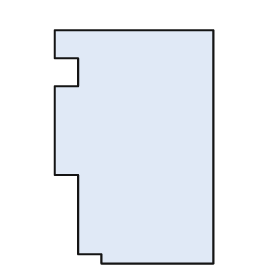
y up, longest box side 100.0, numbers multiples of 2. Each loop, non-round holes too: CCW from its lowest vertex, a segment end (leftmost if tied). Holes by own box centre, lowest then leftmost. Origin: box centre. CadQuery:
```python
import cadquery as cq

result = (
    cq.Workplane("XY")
    .moveTo(-14.0, -50.0)
    .lineTo(34.0, -50.0)
    .lineTo(34.0, 50.0)
    .lineTo(-34.0, 50.0)
    .lineTo(-34.0, 38.0)
    .lineTo(-24.0, 38.0)
    .lineTo(-24.0, 26.0)
    .lineTo(-34.0, 26.0)
    .lineTo(-34.0, -12.0)
    .lineTo(-24.0, -12.0)
    .lineTo(-24.0, -46.0)
    .lineTo(-14.0, -46.0)
    .close()
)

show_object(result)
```